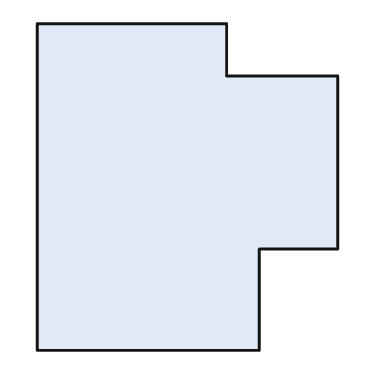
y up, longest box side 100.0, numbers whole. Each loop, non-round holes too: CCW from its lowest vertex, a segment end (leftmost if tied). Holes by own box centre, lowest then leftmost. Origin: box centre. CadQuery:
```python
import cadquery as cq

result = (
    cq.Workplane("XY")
    .moveTo(-46.0, -50.0)
    .lineTo(22.0, -50.0)
    .lineTo(22.0, -19.0)
    .lineTo(46.0, -19.0)
    .lineTo(46.0, 34.0)
    .lineTo(12.0, 34.0)
    .lineTo(12.0, 50.0)
    .lineTo(-46.0, 50.0)
    .close()
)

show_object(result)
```